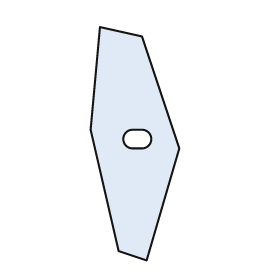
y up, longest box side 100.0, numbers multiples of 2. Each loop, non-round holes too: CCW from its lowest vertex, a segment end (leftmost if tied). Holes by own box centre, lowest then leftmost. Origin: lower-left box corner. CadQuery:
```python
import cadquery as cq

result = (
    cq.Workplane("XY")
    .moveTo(24.0, 0.0)
    .lineTo(38.0, 48.0)
    .lineTo(22.0, 96.0)
    .lineTo(4.0, 100.0)
    .lineTo(0.0, 56.0)
    .lineTo(12.0, 4.0)
    .close()
    .moveTo(18.0, 48.0)
    .lineTo(22.0, 48.0)
    .threePointArc((26.0, 52.0), (22.0, 56.0))
    .lineTo(18.0, 56.0)
    .threePointArc((14.0, 52.0), (18.0, 48.0))
    .close()
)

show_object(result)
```